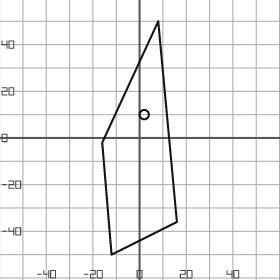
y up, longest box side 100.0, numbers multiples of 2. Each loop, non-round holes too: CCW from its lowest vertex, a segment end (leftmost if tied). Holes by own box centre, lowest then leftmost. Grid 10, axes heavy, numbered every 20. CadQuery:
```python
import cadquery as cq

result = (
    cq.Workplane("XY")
    .moveTo(-12.0, -50.0)
    .lineTo(16.0, -36.0)
    .lineTo(8.0, 50.0)
    .lineTo(-16.0, -2.0)
    .close()
    .moveTo(2.0, 10.0)
    .circle(2.0)
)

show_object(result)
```